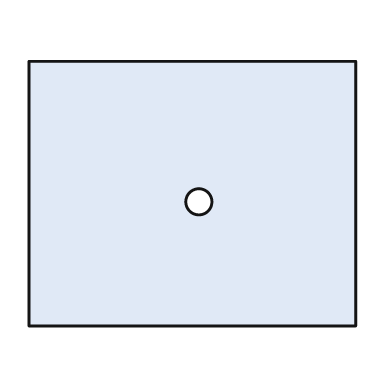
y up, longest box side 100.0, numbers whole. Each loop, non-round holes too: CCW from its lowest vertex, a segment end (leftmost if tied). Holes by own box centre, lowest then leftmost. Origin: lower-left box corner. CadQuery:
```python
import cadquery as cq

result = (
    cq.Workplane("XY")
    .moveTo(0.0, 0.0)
    .lineTo(100.0, 0.0)
    .lineTo(100.0, 81.0)
    .lineTo(0.0, 81.0)
    .close()
    .moveTo(52.0, 38.0)
    .circle(4.0)
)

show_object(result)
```